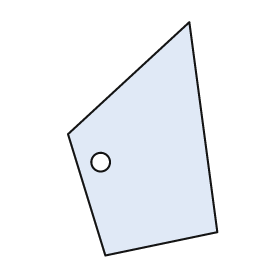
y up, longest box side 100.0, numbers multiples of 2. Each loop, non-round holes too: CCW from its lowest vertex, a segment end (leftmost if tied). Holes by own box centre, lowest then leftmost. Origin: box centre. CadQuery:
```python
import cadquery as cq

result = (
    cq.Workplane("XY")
    .moveTo(-16.0, -50.0)
    .lineTo(32.0, -40.0)
    .lineTo(20.0, 50.0)
    .lineTo(-32.0, 2.0)
    .close()
    .moveTo(-18.0, -10.0)
    .circle(4.0)
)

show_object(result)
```